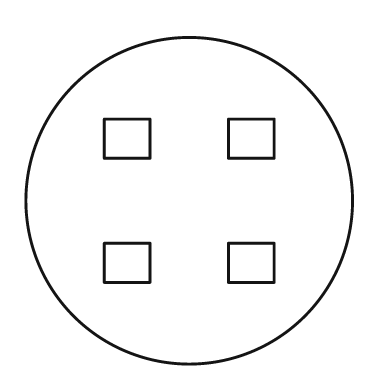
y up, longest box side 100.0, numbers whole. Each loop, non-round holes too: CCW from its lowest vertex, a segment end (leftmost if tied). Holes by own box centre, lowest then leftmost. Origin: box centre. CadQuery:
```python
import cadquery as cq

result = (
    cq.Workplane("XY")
    .moveTo(0.0, 0.0)
    .circle(50.0)
    .moveTo(-26.0, -25.0)
    .lineTo(-12.0, -25.0)
    .lineTo(-12.0, -13.0)
    .lineTo(-26.0, -13.0)
    .close()
    .moveTo(12.0, -25.0)
    .lineTo(26.0, -25.0)
    .lineTo(26.0, -13.0)
    .lineTo(12.0, -13.0)
    .close()
    .moveTo(-26.0, 13.0)
    .lineTo(-12.0, 13.0)
    .lineTo(-12.0, 25.0)
    .lineTo(-26.0, 25.0)
    .close()
    .moveTo(12.0, 13.0)
    .lineTo(26.0, 13.0)
    .lineTo(26.0, 25.0)
    .lineTo(12.0, 25.0)
    .close()
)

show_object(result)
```